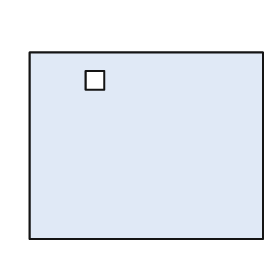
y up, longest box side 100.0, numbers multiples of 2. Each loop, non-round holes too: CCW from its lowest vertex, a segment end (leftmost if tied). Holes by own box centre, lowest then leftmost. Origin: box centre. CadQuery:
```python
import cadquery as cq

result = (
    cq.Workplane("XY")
    .moveTo(-50.0, -40.0)
    .lineTo(50.0, -40.0)
    .lineTo(50.0, 40.0)
    .lineTo(-50.0, 40.0)
    .close()
    .moveTo(-26.0, 24.0)
    .lineTo(-18.0, 24.0)
    .lineTo(-18.0, 32.0)
    .lineTo(-26.0, 32.0)
    .close()
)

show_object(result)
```